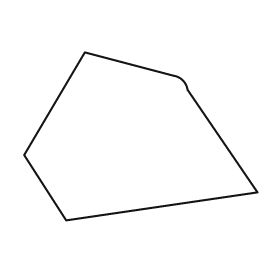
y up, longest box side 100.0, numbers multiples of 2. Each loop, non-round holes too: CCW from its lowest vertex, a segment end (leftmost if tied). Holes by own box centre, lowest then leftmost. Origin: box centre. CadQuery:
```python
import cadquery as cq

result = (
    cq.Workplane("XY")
    .moveTo(-32.0, -36.0)
    .lineTo(50.0, -24.0)
    .lineTo(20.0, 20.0)
    .threePointArc((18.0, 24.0), (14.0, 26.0))
    .lineTo(-24.0, 36.0)
    .lineTo(-50.0, -8.0)
    .close()
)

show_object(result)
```